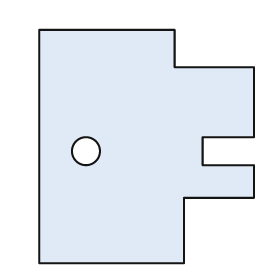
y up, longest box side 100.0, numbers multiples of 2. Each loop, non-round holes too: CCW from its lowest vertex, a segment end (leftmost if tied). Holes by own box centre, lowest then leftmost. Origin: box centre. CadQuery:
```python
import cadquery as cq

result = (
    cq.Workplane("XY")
    .moveTo(-46.0, -50.0)
    .lineTo(16.0, -50.0)
    .lineTo(16.0, -22.0)
    .lineTo(46.0, -22.0)
    .lineTo(46.0, -8.0)
    .lineTo(24.0, -8.0)
    .lineTo(24.0, 4.0)
    .lineTo(46.0, 4.0)
    .lineTo(46.0, 34.0)
    .lineTo(12.0, 34.0)
    .lineTo(12.0, 50.0)
    .lineTo(-46.0, 50.0)
    .close()
    .moveTo(-26.0, -2.0)
    .circle(6.0)
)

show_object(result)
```